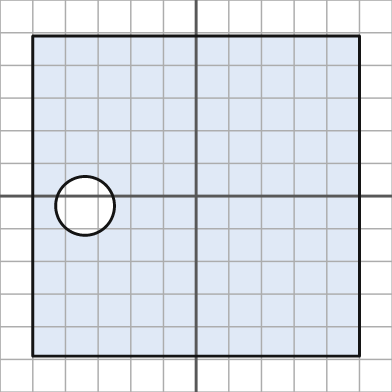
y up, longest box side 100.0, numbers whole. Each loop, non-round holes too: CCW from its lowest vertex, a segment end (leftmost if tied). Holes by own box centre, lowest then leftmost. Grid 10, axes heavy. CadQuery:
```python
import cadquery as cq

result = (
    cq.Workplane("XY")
    .moveTo(-50.0, -49.0)
    .lineTo(50.0, -49.0)
    .lineTo(50.0, 49.0)
    .lineTo(-50.0, 49.0)
    .close()
    .moveTo(-34.0, -3.0)
    .circle(9.0)
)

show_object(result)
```